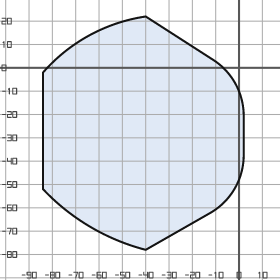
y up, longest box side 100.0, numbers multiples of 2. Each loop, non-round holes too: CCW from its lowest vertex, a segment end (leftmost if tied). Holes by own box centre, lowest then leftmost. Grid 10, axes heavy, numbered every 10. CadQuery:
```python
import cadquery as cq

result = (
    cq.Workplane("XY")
    .moveTo(-40.0, -78.0)
    .lineTo(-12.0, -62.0)
    .threePointArc((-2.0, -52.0), (2.0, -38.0))
    .lineTo(2.0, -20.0)
    .threePointArc((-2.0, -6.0), (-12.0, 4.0))
    .lineTo(-40.0, 22.0)
    .threePointArc((-64.0, 14.0), (-84.0, -2.0))
    .lineTo(-84.0, -52.0)
    .threePointArc((-64.0, -68.0), (-40.0, -78.0))
    .close()
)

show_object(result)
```